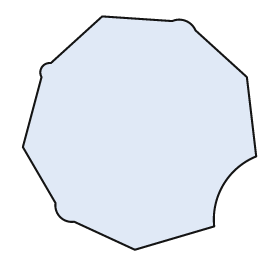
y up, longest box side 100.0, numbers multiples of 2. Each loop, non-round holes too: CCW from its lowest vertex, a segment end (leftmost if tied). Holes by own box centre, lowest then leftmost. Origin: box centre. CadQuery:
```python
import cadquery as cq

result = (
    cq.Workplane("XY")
    .moveTo(-2.0, -50.0)
    .lineTo(32.0, -40.0)
    .threePointArc((36.0, -22.0), (50.0, -10.0))
    .lineTo(46.0, 24.0)
    .lineTo(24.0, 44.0)
    .threePointArc((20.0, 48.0), (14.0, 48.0))
    .lineTo(-16.0, 50.0)
    .lineTo(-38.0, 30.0)
    .threePointArc((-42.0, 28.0), (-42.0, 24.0))
    .lineTo(-50.0, -6.0)
    .lineTo(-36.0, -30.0)
    .threePointArc((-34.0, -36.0), (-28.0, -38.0))
    .close()
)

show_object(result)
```